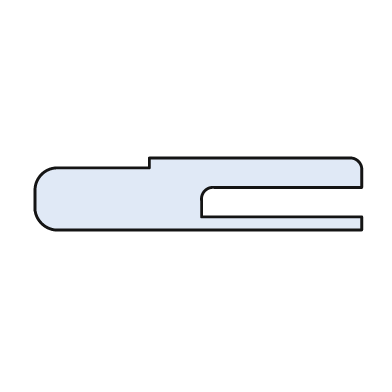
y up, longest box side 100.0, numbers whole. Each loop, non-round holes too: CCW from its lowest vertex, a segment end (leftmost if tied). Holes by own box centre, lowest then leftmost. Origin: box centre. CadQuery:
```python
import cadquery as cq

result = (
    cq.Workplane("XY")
    .moveTo(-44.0, -11.0)
    .lineTo(50.0, -11.0)
    .lineTo(50.0, -7.0)
    .lineTo(1.0, -7.0)
    .lineTo(1.0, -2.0)
    .threePointArc((2.0, 1.0), (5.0, 2.0))
    .lineTo(50.0, 2.0)
    .lineTo(50.0, 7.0)
    .threePointArc((49.0, 10.0), (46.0, 11.0))
    .lineTo(-15.0, 11.0)
    .lineTo(-15.0, 8.0)
    .lineTo(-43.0, 8.0)
    .threePointArc((-48.0, 6.0), (-50.0, 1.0))
    .lineTo(-50.0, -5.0)
    .threePointArc((-48.0, -9.0), (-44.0, -11.0))
    .close()
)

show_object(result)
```